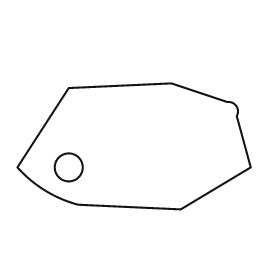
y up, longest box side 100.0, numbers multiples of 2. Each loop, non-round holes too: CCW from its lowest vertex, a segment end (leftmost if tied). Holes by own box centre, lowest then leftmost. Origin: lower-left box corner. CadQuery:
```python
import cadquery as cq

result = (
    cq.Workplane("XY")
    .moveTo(70.0, 0.0)
    .lineTo(100.0, 18.0)
    .lineTo(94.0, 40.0)
    .threePointArc((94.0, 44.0), (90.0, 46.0))
    .lineTo(66.0, 54.0)
    .lineTo(22.0, 52.0)
    .lineTo(0.0, 18.0)
    .threePointArc((12.0, 8.0), (26.0, 2.0))
    .close()
    .moveTo(22.0, 18.0)
    .circle(6.0)
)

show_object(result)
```